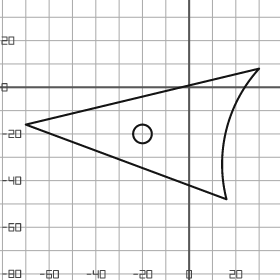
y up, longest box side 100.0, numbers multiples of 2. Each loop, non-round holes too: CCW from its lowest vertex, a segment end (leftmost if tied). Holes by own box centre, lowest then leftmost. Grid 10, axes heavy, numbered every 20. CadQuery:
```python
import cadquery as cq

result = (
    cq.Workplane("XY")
    .moveTo(16.0, -48.0)
    .threePointArc((16.0, -18.0), (30.0, 8.0))
    .lineTo(-70.0, -16.0)
    .close()
    .moveTo(-20.0, -20.0)
    .circle(4.0)
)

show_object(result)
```